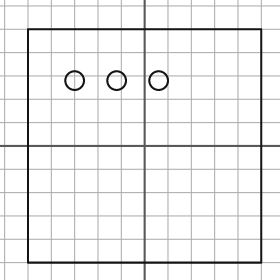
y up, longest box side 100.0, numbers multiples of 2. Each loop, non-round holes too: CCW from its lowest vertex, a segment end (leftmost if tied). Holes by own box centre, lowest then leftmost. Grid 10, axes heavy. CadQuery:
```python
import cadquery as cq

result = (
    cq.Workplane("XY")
    .moveTo(-50.0, -50.0)
    .lineTo(50.0, -50.0)
    .lineTo(50.0, 50.0)
    .lineTo(-50.0, 50.0)
    .close()
    .moveTo(-30.0, 28.0)
    .circle(4.0)
    .moveTo(-12.0, 28.0)
    .circle(4.0)
    .moveTo(6.0, 28.0)
    .circle(4.0)
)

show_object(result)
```